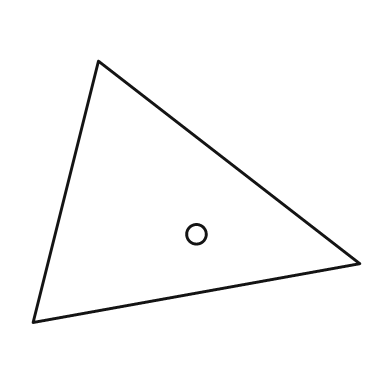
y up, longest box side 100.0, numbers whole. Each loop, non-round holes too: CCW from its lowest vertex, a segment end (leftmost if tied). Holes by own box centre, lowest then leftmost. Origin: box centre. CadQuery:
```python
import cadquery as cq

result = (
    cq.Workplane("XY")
    .moveTo(-50.0, -40.0)
    .lineTo(50.0, -22.0)
    .lineTo(-30.0, 40.0)
    .close()
    .moveTo(0.0, -13.0)
    .circle(3.0)
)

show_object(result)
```